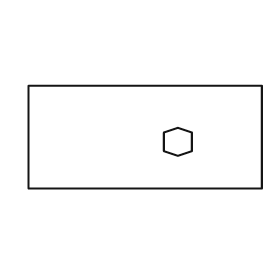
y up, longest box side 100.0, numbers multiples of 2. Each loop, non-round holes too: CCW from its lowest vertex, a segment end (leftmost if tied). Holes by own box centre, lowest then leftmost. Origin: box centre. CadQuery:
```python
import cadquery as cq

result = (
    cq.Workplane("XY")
    .moveTo(-50.0, -22.0)
    .lineTo(50.0, -22.0)
    .lineTo(50.0, 22.0)
    .lineTo(-50.0, 22.0)
    .close()
    .moveTo(14.0, -8.0)
    .lineTo(20.0, -6.0)
    .lineTo(20.0, 2.0)
    .lineTo(14.0, 4.0)
    .lineTo(8.0, 2.0)
    .lineTo(8.0, -6.0)
    .close()
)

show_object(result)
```